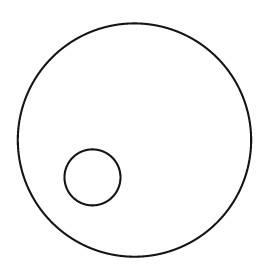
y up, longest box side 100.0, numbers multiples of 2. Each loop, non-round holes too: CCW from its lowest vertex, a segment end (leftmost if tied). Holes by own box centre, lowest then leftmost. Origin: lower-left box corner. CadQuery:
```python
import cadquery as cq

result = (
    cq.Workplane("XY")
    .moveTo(50.0, 50.0)
    .circle(50.0)
    .moveTo(32.0, 34.0)
    .circle(12.0)
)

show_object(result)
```